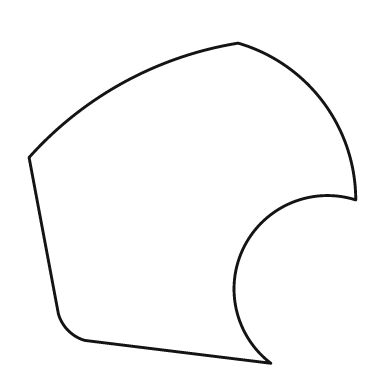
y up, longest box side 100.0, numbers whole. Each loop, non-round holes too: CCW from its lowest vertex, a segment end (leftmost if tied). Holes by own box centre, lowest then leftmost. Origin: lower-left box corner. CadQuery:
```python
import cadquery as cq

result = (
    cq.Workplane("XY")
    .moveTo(74.0, 0.0)
    .threePointArc((66.0, 36.0), (100.0, 50.0))
    .threePointArc((90.0, 80.0), (64.0, 98.0))
    .threePointArc((29.0, 86.0), (0.0, 63.0))
    .lineTo(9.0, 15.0)
    .threePointArc((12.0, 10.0), (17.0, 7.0))
    .close()
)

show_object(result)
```